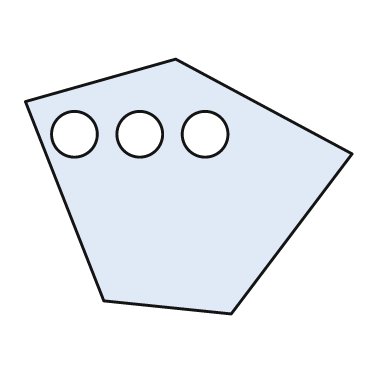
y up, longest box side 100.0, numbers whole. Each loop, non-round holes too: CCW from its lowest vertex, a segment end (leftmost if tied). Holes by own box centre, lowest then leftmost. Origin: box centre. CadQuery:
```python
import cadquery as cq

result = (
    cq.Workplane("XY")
    .moveTo(13.0, -39.0)
    .lineTo(50.0, 10.0)
    .lineTo(-4.0, 39.0)
    .lineTo(-50.0, 26.0)
    .lineTo(-26.0, -35.0)
    .close()
    .moveTo(-35.0, 16.0)
    .circle(7.0)
    .moveTo(-15.0, 16.0)
    .circle(7.0)
    .moveTo(5.0, 16.0)
    .circle(7.0)
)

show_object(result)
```